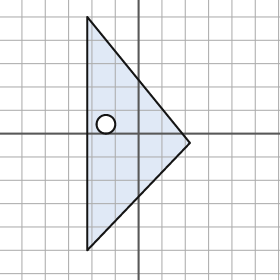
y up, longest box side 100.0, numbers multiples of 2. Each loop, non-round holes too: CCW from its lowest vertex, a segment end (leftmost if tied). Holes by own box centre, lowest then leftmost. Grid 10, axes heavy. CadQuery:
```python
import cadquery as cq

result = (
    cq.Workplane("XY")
    .moveTo(-22.0, -50.0)
    .lineTo(22.0, -4.0)
    .lineTo(-22.0, 50.0)
    .close()
    .moveTo(-14.0, 4.0)
    .circle(4.0)
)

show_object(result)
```